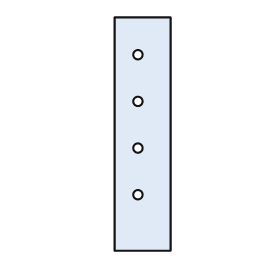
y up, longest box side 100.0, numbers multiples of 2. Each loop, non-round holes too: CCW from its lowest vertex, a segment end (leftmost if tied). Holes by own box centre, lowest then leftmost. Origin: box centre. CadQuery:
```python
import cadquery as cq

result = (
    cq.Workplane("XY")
    .moveTo(-12.0, -50.0)
    .lineTo(12.0, -50.0)
    .lineTo(12.0, 50.0)
    .lineTo(-12.0, 50.0)
    .close()
    .moveTo(-2.0, -26.0)
    .circle(2.0)
    .moveTo(-2.0, -6.0)
    .circle(2.0)
    .moveTo(-2.0, 14.0)
    .circle(2.0)
    .moveTo(-2.0, 34.0)
    .circle(2.0)
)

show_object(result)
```